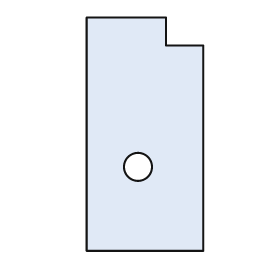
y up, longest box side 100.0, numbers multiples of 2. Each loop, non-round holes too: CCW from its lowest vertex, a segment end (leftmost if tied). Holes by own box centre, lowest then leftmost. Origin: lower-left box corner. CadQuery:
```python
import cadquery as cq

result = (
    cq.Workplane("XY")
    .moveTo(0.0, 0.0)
    .lineTo(50.0, 0.0)
    .lineTo(50.0, 88.0)
    .lineTo(34.0, 88.0)
    .lineTo(34.0, 100.0)
    .lineTo(0.0, 100.0)
    .close()
    .moveTo(22.0, 36.0)
    .circle(6.0)
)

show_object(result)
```